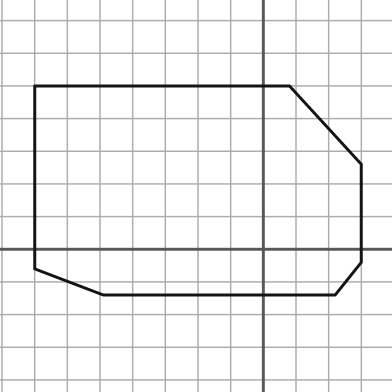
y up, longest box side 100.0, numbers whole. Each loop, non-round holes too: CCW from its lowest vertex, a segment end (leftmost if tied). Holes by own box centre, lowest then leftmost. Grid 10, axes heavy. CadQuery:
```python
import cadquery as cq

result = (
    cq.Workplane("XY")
    .moveTo(-49.0, -14.0)
    .lineTo(22.0, -14.0)
    .lineTo(30.0, -4.0)
    .lineTo(30.0, 26.0)
    .lineTo(8.0, 50.0)
    .lineTo(-70.0, 50.0)
    .lineTo(-70.0, -6.0)
    .close()
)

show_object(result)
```